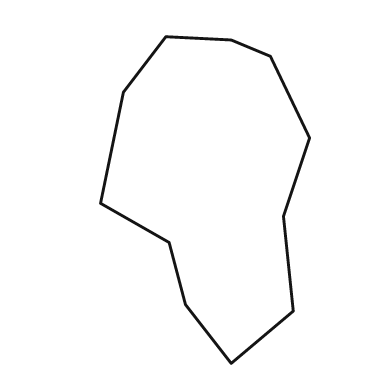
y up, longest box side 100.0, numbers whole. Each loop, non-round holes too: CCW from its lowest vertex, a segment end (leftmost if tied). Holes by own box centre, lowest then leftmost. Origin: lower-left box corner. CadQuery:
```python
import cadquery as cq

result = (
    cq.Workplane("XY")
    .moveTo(40.0, 0.0)
    .lineTo(59.0, 16.0)
    .lineTo(56.0, 45.0)
    .lineTo(64.0, 69.0)
    .lineTo(52.0, 94.0)
    .lineTo(40.0, 99.0)
    .lineTo(20.0, 100.0)
    .lineTo(7.0, 83.0)
    .lineTo(0.0, 49.0)
    .lineTo(21.0, 37.0)
    .lineTo(26.0, 18.0)
    .close()
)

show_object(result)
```